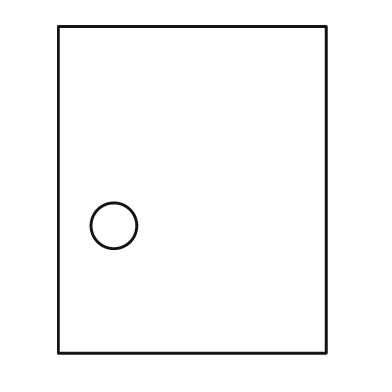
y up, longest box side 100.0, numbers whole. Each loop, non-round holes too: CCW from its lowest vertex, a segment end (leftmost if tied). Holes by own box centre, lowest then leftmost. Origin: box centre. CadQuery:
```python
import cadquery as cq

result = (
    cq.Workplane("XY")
    .moveTo(-41.0, -50.0)
    .lineTo(41.0, -50.0)
    .lineTo(41.0, 50.0)
    .lineTo(-41.0, 50.0)
    .close()
    .moveTo(-24.0, -11.0)
    .circle(7.0)
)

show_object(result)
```